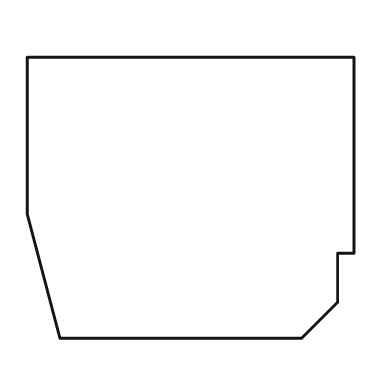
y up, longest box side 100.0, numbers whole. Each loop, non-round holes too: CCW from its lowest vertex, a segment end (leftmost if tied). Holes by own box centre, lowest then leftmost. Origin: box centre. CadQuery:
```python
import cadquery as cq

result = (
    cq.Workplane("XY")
    .moveTo(-40.0, -43.0)
    .lineTo(34.0, -43.0)
    .lineTo(45.0, -32.0)
    .lineTo(45.0, -17.0)
    .lineTo(50.0, -17.0)
    .lineTo(50.0, 43.0)
    .lineTo(-50.0, 43.0)
    .lineTo(-50.0, -5.0)
    .close()
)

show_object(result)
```